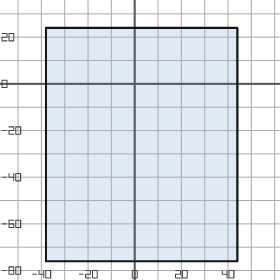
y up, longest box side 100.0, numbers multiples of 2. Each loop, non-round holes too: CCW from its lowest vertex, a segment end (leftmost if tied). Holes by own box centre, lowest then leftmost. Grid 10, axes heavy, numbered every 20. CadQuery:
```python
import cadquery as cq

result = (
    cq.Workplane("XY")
    .moveTo(-38.0, -76.0)
    .lineTo(44.0, -76.0)
    .lineTo(44.0, 24.0)
    .lineTo(-38.0, 24.0)
    .close()
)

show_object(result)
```